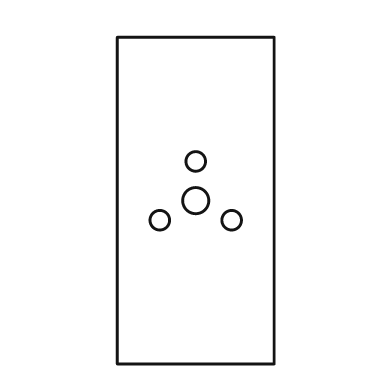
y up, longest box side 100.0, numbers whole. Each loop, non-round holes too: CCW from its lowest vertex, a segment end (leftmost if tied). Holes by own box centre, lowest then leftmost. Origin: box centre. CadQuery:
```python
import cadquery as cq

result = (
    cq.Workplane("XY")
    .moveTo(-24.0, -50.0)
    .lineTo(24.0, -50.0)
    .lineTo(24.0, 50.0)
    .lineTo(-24.0, 50.0)
    .close()
    .moveTo(-11.0, -6.0)
    .circle(3.0)
    .moveTo(11.0, -6.0)
    .circle(3.0)
    .moveTo(0.0, 0.0)
    .circle(4.0)
    .moveTo(0.0, 12.0)
    .circle(3.0)
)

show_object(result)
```